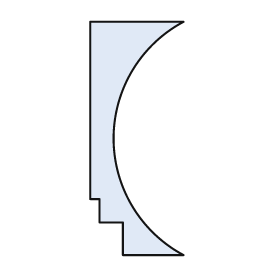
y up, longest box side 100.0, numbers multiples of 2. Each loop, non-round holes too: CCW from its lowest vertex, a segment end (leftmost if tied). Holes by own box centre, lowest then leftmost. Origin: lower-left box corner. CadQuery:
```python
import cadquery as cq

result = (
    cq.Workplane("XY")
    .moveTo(14.0, 0.0)
    .lineTo(40.0, 0.0)
    .threePointArc((10.0, 50.0), (40.0, 100.0))
    .lineTo(0.0, 100.0)
    .lineTo(0.0, 24.0)
    .lineTo(4.0, 24.0)
    .lineTo(4.0, 14.0)
    .lineTo(14.0, 14.0)
    .close()
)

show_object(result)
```